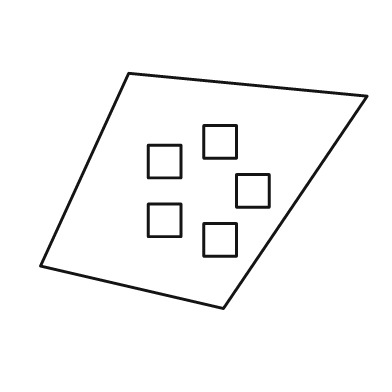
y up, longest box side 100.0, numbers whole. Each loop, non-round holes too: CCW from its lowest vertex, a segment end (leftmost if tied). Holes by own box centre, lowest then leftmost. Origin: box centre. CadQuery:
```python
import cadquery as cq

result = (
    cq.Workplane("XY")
    .moveTo(6.0, -36.0)
    .lineTo(50.0, 29.0)
    .lineTo(-23.0, 36.0)
    .lineTo(-50.0, -23.0)
    .close()
    .moveTo(0.0, -20.0)
    .lineTo(10.0, -20.0)
    .lineTo(10.0, -10.0)
    .lineTo(0.0, -10.0)
    .close()
    .moveTo(-17.0, -14.0)
    .lineTo(-7.0, -14.0)
    .lineTo(-7.0, -4.0)
    .lineTo(-17.0, -4.0)
    .close()
    .moveTo(10.0, -5.0)
    .lineTo(20.0, -5.0)
    .lineTo(20.0, 5.0)
    .lineTo(10.0, 5.0)
    .close()
    .moveTo(-17.0, 4.0)
    .lineTo(-7.0, 4.0)
    .lineTo(-7.0, 14.0)
    .lineTo(-17.0, 14.0)
    .close()
    .moveTo(0.0, 10.0)
    .lineTo(10.0, 10.0)
    .lineTo(10.0, 20.0)
    .lineTo(0.0, 20.0)
    .close()
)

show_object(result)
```